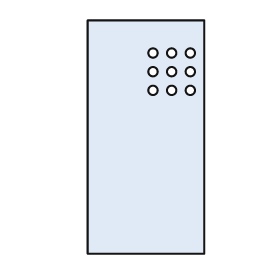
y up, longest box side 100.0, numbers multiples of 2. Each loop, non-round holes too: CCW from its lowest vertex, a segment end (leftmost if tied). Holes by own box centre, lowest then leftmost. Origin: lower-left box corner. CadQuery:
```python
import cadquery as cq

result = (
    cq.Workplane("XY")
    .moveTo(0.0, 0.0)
    .lineTo(50.0, 0.0)
    .lineTo(50.0, 100.0)
    .lineTo(0.0, 100.0)
    .close()
    .moveTo(28.0, 70.0)
    .circle(2.0)
    .moveTo(36.0, 70.0)
    .circle(2.0)
    .moveTo(44.0, 70.0)
    .circle(2.0)
    .moveTo(28.0, 78.0)
    .circle(2.0)
    .moveTo(36.0, 78.0)
    .circle(2.0)
    .moveTo(44.0, 78.0)
    .circle(2.0)
    .moveTo(28.0, 86.0)
    .circle(2.0)
    .moveTo(36.0, 86.0)
    .circle(2.0)
    .moveTo(44.0, 86.0)
    .circle(2.0)
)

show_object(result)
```